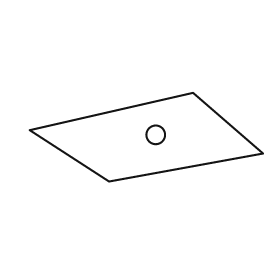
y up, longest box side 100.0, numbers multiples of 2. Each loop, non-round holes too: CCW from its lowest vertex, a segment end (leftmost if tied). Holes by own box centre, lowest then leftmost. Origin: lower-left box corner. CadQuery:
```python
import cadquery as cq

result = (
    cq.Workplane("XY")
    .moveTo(34.0, 0.0)
    .lineTo(100.0, 12.0)
    .lineTo(70.0, 38.0)
    .lineTo(0.0, 22.0)
    .close()
    .moveTo(54.0, 20.0)
    .circle(4.0)
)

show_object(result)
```